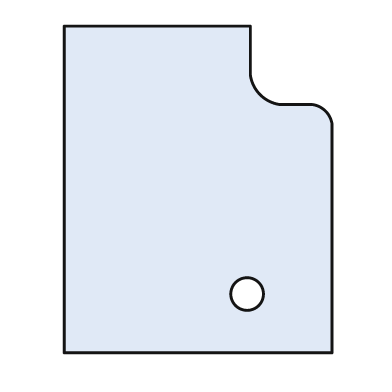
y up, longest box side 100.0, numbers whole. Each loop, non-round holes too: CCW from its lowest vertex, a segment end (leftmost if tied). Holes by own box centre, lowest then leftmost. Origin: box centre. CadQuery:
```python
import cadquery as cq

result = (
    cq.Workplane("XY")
    .moveTo(-41.0, -50.0)
    .lineTo(41.0, -50.0)
    .lineTo(41.0, 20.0)
    .threePointArc((39.0, 24.0), (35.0, 26.0))
    .lineTo(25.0, 26.0)
    .threePointArc((19.0, 29.0), (16.0, 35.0))
    .lineTo(16.0, 50.0)
    .lineTo(-41.0, 50.0)
    .close()
    .moveTo(15.0, -32.0)
    .circle(5.0)
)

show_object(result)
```